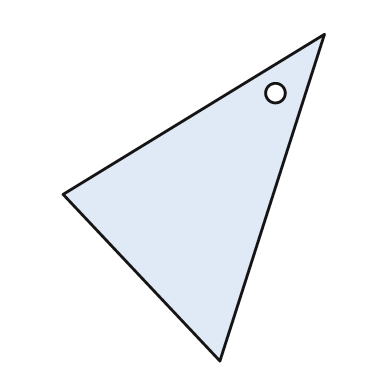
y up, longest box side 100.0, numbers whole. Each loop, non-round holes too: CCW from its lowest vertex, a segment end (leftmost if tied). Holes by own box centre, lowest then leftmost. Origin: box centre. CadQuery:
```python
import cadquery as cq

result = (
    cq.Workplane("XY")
    .moveTo(8.0, -50.0)
    .lineTo(40.0, 50.0)
    .lineTo(-40.0, 1.0)
    .close()
    .moveTo(25.0, 32.0)
    .circle(3.0)
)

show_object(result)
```